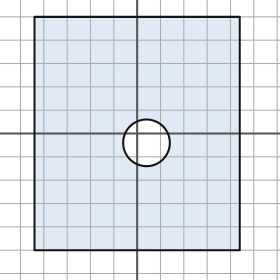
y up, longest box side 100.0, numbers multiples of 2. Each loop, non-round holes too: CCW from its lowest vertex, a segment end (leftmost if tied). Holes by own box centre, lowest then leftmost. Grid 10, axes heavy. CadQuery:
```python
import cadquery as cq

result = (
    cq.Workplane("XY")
    .moveTo(-44.0, -50.0)
    .lineTo(44.0, -50.0)
    .lineTo(44.0, 50.0)
    .lineTo(-44.0, 50.0)
    .close()
    .moveTo(4.0, -4.0)
    .circle(10.0)
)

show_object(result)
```